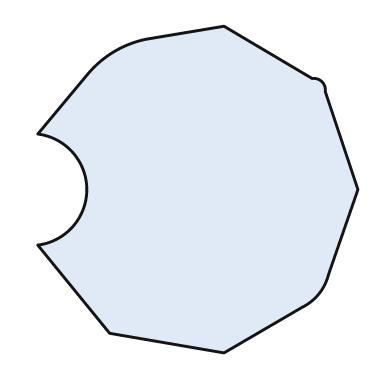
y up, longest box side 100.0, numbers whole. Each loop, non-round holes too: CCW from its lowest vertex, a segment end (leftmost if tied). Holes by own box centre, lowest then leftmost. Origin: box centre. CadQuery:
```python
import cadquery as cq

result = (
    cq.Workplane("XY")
    .moveTo(8.0, -50.0)
    .lineTo(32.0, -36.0)
    .threePointArc((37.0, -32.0), (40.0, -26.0))
    .lineTo(49.0, 0.0)
    .lineTo(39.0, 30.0)
    .threePointArc((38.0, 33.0), (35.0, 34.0))
    .lineTo(8.0, 50.0)
    .lineTo(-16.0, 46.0)
    .threePointArc((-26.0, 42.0), (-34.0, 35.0))
    .lineTo(-49.0, 17.0)
    .threePointArc((-34.0, 0.0), (-49.0, -17.0))
    .lineTo(-27.0, -44.0)
    .close()
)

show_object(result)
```